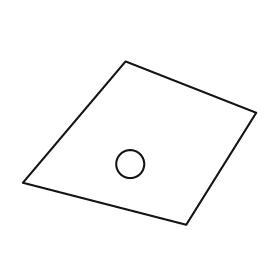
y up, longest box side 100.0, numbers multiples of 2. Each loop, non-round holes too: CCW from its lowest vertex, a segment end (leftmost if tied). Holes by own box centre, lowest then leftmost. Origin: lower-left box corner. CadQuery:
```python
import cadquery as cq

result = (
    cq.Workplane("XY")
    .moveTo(70.0, 0.0)
    .lineTo(100.0, 48.0)
    .lineTo(44.0, 70.0)
    .lineTo(0.0, 18.0)
    .close()
    .moveTo(46.0, 26.0)
    .circle(6.0)
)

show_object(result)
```